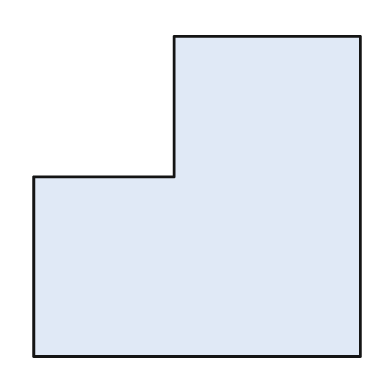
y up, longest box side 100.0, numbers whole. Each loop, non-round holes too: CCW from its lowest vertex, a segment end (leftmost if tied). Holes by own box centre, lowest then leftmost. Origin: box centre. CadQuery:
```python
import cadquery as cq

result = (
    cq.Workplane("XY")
    .moveTo(-50.0, -49.0)
    .lineTo(50.0, -49.0)
    .lineTo(50.0, 49.0)
    .lineTo(-7.0, 49.0)
    .lineTo(-7.0, 6.0)
    .lineTo(-50.0, 6.0)
    .close()
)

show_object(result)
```